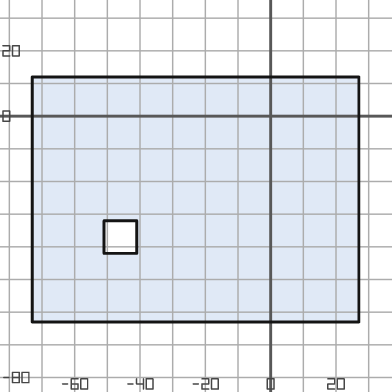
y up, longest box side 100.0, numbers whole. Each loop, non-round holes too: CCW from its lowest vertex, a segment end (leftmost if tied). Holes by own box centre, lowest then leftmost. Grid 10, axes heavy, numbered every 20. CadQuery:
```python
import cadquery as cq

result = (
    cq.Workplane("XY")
    .moveTo(-73.0, -63.0)
    .lineTo(27.0, -63.0)
    .lineTo(27.0, 12.0)
    .lineTo(-73.0, 12.0)
    .close()
    .moveTo(-51.0, -42.0)
    .lineTo(-41.0, -42.0)
    .lineTo(-41.0, -32.0)
    .lineTo(-51.0, -32.0)
    .close()
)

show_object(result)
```